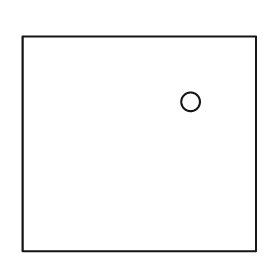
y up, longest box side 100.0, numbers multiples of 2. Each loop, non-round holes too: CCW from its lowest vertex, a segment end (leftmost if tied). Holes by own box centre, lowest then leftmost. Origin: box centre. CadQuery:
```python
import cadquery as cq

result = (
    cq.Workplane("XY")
    .moveTo(-50.0, -46.0)
    .lineTo(50.0, -46.0)
    .lineTo(50.0, 46.0)
    .lineTo(-50.0, 46.0)
    .close()
    .moveTo(22.0, 18.0)
    .circle(4.0)
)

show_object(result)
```